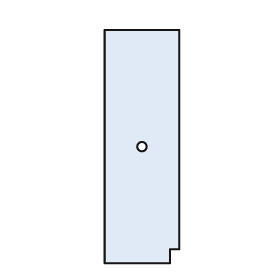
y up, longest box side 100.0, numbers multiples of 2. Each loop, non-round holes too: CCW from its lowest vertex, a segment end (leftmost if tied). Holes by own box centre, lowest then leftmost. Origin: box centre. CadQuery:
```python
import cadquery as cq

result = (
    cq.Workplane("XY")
    .moveTo(-16.0, -50.0)
    .lineTo(12.0, -50.0)
    .lineTo(12.0, -44.0)
    .lineTo(16.0, -44.0)
    .lineTo(16.0, 50.0)
    .lineTo(-16.0, 50.0)
    .close()
    .moveTo(0.0, 0.0)
    .circle(2.0)
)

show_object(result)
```